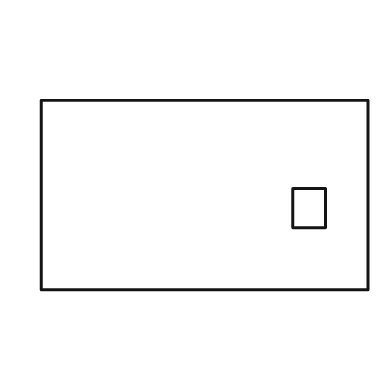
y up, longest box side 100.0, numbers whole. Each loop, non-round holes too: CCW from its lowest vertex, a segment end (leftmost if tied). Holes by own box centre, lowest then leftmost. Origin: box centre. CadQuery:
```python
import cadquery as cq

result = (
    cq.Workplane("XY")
    .moveTo(-50.0, -29.0)
    .lineTo(50.0, -29.0)
    .lineTo(50.0, 29.0)
    .lineTo(-50.0, 29.0)
    .close()
    .moveTo(27.0, -10.0)
    .lineTo(37.0, -10.0)
    .lineTo(37.0, 2.0)
    .lineTo(27.0, 2.0)
    .close()
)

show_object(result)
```